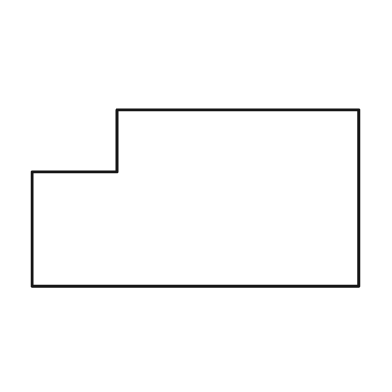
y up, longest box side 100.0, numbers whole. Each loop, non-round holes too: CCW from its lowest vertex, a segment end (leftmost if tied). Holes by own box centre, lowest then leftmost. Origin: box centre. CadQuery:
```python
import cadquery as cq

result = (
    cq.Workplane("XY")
    .moveTo(-50.0, -27.0)
    .lineTo(50.0, -27.0)
    .lineTo(50.0, 27.0)
    .lineTo(-24.0, 27.0)
    .lineTo(-24.0, 8.0)
    .lineTo(-50.0, 8.0)
    .close()
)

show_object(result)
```